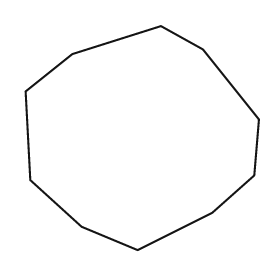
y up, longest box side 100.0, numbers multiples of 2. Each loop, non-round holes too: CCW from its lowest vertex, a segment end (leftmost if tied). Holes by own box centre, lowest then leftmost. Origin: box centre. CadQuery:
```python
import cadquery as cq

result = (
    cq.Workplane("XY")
    .moveTo(-2.0, -48.0)
    .lineTo(30.0, -32.0)
    .lineTo(48.0, -16.0)
    .lineTo(50.0, 8.0)
    .lineTo(26.0, 38.0)
    .lineTo(8.0, 48.0)
    .lineTo(-30.0, 36.0)
    .lineTo(-50.0, 20.0)
    .lineTo(-48.0, -18.0)
    .lineTo(-26.0, -38.0)
    .close()
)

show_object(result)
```